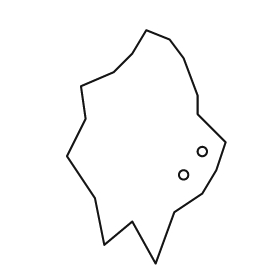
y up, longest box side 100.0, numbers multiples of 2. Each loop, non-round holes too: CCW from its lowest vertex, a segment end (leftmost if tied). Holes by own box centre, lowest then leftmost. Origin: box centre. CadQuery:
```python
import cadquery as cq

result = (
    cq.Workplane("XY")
    .moveTo(4.0, -50.0)
    .lineTo(12.0, -28.0)
    .lineTo(24.0, -20.0)
    .lineTo(30.0, -10.0)
    .lineTo(34.0, 2.0)
    .lineTo(22.0, 14.0)
    .lineTo(22.0, 22.0)
    .lineTo(16.0, 38.0)
    .lineTo(10.0, 46.0)
    .lineTo(0.0, 50.0)
    .lineTo(-6.0, 40.0)
    .lineTo(-14.0, 32.0)
    .lineTo(-28.0, 26.0)
    .lineTo(-26.0, 12.0)
    .lineTo(-34.0, -4.0)
    .lineTo(-22.0, -22.0)
    .lineTo(-18.0, -42.0)
    .lineTo(-6.0, -32.0)
    .close()
    .moveTo(16.0, -12.0)
    .circle(2.0)
    .moveTo(24.0, -2.0)
    .circle(2.0)
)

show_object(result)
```